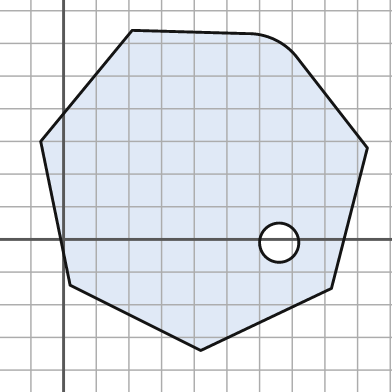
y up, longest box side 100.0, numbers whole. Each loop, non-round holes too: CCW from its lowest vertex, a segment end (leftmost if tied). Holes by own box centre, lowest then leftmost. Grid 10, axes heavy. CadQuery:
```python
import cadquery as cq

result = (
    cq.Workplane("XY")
    .moveTo(42.0, -34.0)
    .lineTo(82.0, -15.0)
    .lineTo(93.0, 28.0)
    .lineTo(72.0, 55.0)
    .threePointArc((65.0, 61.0), (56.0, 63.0))
    .lineTo(21.0, 64.0)
    .lineTo(-7.0, 30.0)
    .lineTo(2.0, -14.0)
    .close()
    .moveTo(66.0, -1.0)
    .circle(6.0)
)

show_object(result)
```